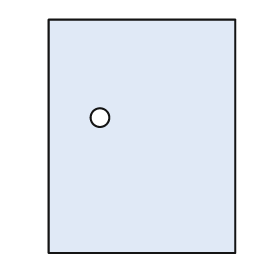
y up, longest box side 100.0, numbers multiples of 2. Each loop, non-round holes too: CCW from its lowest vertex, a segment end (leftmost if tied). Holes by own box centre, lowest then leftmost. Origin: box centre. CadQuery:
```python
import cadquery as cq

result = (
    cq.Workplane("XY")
    .moveTo(-40.0, -50.0)
    .lineTo(40.0, -50.0)
    .lineTo(40.0, 50.0)
    .lineTo(-40.0, 50.0)
    .close()
    .moveTo(-18.0, 8.0)
    .circle(4.0)
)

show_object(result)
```